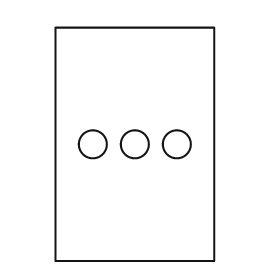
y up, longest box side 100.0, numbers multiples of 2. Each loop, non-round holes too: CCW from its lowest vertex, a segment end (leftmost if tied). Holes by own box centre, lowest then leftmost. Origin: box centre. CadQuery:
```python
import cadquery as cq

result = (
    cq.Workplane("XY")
    .moveTo(-34.0, -50.0)
    .lineTo(34.0, -50.0)
    .lineTo(34.0, 50.0)
    .lineTo(-34.0, 50.0)
    .close()
    .moveTo(-18.0, 0.0)
    .circle(6.0)
    .moveTo(0.0, 0.0)
    .circle(6.0)
    .moveTo(18.0, 0.0)
    .circle(6.0)
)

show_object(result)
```